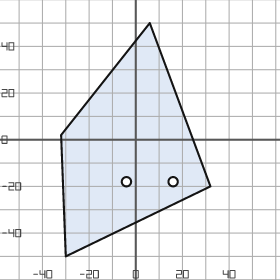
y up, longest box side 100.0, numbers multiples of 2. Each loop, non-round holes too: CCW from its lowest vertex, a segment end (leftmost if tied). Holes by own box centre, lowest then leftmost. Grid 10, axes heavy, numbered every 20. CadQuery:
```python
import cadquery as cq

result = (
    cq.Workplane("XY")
    .moveTo(-30.0, -50.0)
    .lineTo(32.0, -20.0)
    .lineTo(6.0, 50.0)
    .lineTo(-32.0, 2.0)
    .close()
    .moveTo(-4.0, -18.0)
    .circle(2.0)
    .moveTo(16.0, -18.0)
    .circle(2.0)
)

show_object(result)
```